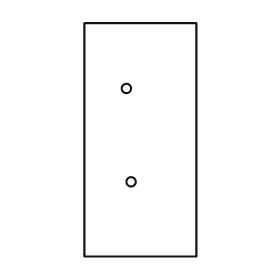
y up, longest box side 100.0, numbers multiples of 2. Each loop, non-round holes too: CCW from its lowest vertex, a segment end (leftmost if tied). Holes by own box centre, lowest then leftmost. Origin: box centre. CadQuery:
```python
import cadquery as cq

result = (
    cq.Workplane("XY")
    .moveTo(-24.0, -50.0)
    .lineTo(24.0, -50.0)
    .lineTo(24.0, 50.0)
    .lineTo(-24.0, 50.0)
    .close()
    .moveTo(-4.0, -18.0)
    .circle(2.0)
    .moveTo(-6.0, 22.0)
    .circle(2.0)
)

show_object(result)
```